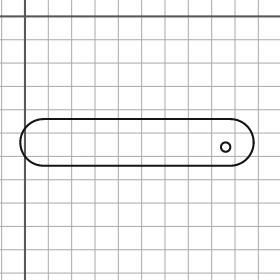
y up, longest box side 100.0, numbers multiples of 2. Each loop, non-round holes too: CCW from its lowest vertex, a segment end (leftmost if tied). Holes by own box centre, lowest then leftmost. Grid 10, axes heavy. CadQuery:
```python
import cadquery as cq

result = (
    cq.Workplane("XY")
    .moveTo(8.0, -64.0)
    .lineTo(88.0, -64.0)
    .threePointArc((98.0, -54.0), (88.0, -44.0))
    .lineTo(8.0, -44.0)
    .threePointArc((-2.0, -54.0), (8.0, -64.0))
    .close()
    .moveTo(86.0, -56.0)
    .circle(2.0)
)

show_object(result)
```